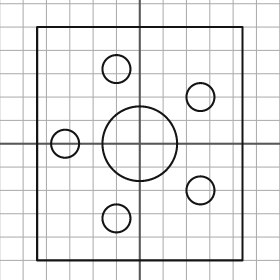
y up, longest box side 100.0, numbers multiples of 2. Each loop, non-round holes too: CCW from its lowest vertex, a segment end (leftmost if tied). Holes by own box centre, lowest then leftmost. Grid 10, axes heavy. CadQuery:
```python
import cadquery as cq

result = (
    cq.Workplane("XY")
    .moveTo(-44.0, -50.0)
    .lineTo(44.0, -50.0)
    .lineTo(44.0, 50.0)
    .lineTo(-44.0, 50.0)
    .close()
    .moveTo(-10.0, -32.0)
    .circle(6.0)
    .moveTo(26.0, -20.0)
    .circle(6.0)
    .moveTo(-32.0, 0.0)
    .circle(6.0)
    .moveTo(0.0, 0.0)
    .circle(16.0)
    .moveTo(26.0, 20.0)
    .circle(6.0)
    .moveTo(-10.0, 32.0)
    .circle(6.0)
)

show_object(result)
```